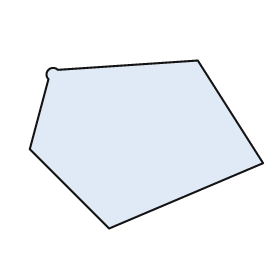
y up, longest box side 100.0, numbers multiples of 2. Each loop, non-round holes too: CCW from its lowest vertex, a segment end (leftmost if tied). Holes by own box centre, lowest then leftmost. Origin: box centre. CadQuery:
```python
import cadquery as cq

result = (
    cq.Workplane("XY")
    .moveTo(-16.0, -36.0)
    .lineTo(50.0, -8.0)
    .lineTo(22.0, 36.0)
    .lineTo(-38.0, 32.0)
    .threePointArc((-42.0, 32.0), (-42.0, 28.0))
    .lineTo(-50.0, -2.0)
    .close()
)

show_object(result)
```